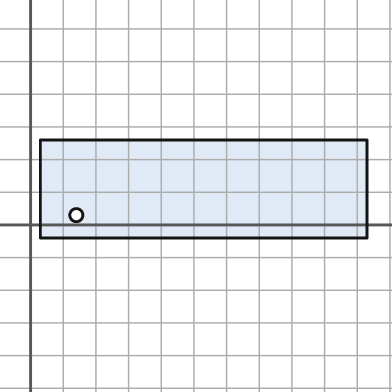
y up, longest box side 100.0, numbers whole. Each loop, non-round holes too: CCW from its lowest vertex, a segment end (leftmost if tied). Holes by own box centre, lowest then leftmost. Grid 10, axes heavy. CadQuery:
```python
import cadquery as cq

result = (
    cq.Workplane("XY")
    .moveTo(3.0, -4.0)
    .lineTo(103.0, -4.0)
    .lineTo(103.0, 26.0)
    .lineTo(3.0, 26.0)
    .close()
    .moveTo(14.0, 3.0)
    .circle(2.0)
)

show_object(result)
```